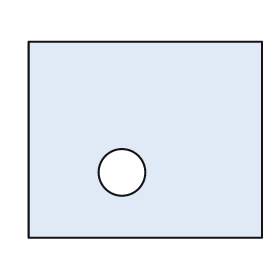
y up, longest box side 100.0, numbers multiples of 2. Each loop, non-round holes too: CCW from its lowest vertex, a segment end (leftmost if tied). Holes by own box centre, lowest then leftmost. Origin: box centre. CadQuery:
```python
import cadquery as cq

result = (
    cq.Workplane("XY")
    .moveTo(-50.0, -42.0)
    .lineTo(50.0, -42.0)
    .lineTo(50.0, 42.0)
    .lineTo(-50.0, 42.0)
    .close()
    .moveTo(-10.0, -14.0)
    .circle(10.0)
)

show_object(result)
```